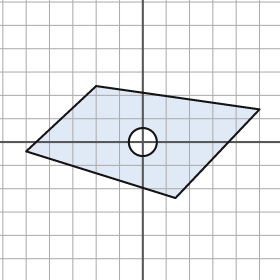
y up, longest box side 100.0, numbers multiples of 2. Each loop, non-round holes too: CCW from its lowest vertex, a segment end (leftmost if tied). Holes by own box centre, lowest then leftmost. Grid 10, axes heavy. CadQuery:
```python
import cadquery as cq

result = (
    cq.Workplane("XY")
    .moveTo(14.0, -24.0)
    .lineTo(50.0, 14.0)
    .lineTo(-20.0, 24.0)
    .lineTo(-50.0, -4.0)
    .close()
    .moveTo(0.0, 0.0)
    .circle(6.0)
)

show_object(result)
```